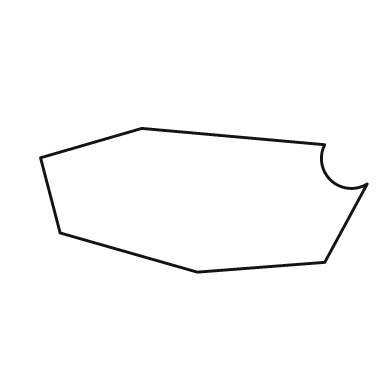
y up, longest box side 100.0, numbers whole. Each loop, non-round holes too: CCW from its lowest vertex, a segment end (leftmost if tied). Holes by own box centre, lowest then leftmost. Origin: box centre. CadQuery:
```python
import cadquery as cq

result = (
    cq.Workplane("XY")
    .moveTo(-2.0, -22.0)
    .lineTo(37.0, -19.0)
    .lineTo(50.0, 5.0)
    .threePointArc((39.0, 6.0), (37.0, 17.0))
    .lineTo(-19.0, 22.0)
    .lineTo(-50.0, 13.0)
    .lineTo(-44.0, -10.0)
    .close()
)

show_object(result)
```